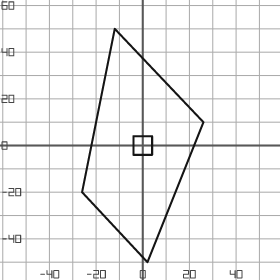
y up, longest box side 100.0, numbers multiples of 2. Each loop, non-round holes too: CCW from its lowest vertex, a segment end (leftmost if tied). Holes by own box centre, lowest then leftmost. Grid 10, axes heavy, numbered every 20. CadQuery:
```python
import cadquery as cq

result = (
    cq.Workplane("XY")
    .moveTo(2.0, -50.0)
    .lineTo(26.0, 10.0)
    .lineTo(-12.0, 50.0)
    .lineTo(-26.0, -20.0)
    .close()
    .moveTo(-4.0, -4.0)
    .lineTo(4.0, -4.0)
    .lineTo(4.0, 4.0)
    .lineTo(-4.0, 4.0)
    .close()
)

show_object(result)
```